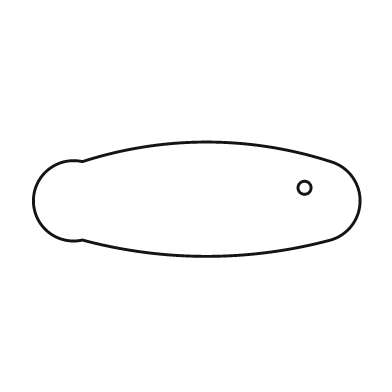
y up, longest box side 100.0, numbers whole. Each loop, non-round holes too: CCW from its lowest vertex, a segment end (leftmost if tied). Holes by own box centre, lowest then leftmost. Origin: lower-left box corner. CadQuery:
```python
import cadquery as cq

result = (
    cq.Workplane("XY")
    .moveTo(15.0, 5.0)
    .threePointArc((53.0, 0.0), (91.0, 5.0))
    .threePointArc((100.0, 17.0), (91.0, 29.0))
    .threePointArc((53.0, 35.0), (15.0, 29.0))
    .threePointArc((0.0, 17.0), (15.0, 5.0))
    .close()
    .moveTo(83.0, 21.0)
    .circle(2.0)
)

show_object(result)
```